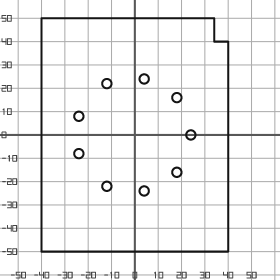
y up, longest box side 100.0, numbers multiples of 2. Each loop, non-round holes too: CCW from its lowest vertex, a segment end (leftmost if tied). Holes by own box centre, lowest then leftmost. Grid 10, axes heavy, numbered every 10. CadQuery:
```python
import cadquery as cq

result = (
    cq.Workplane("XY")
    .moveTo(-40.0, -50.0)
    .lineTo(40.0, -50.0)
    .lineTo(40.0, 40.0)
    .lineTo(34.0, 40.0)
    .lineTo(34.0, 50.0)
    .lineTo(-40.0, 50.0)
    .close()
    .moveTo(4.0, -24.0)
    .circle(2.0)
    .moveTo(-12.0, -22.0)
    .circle(2.0)
    .moveTo(18.0, -16.0)
    .circle(2.0)
    .moveTo(-24.0, -8.0)
    .circle(2.0)
    .moveTo(24.0, 0.0)
    .circle(2.0)
    .moveTo(-24.0, 8.0)
    .circle(2.0)
    .moveTo(18.0, 16.0)
    .circle(2.0)
    .moveTo(-12.0, 22.0)
    .circle(2.0)
    .moveTo(4.0, 24.0)
    .circle(2.0)
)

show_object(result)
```